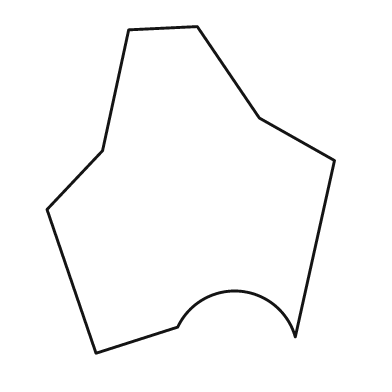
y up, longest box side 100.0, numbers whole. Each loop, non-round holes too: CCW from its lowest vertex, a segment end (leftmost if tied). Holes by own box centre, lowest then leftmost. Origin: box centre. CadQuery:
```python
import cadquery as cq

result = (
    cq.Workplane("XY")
    .moveTo(-29.0, -50.0)
    .lineTo(-4.0, -42.0)
    .threePointArc((15.0, -31.0), (32.0, -45.0))
    .lineTo(44.0, 9.0)
    .lineTo(21.0, 22.0)
    .lineTo(2.0, 50.0)
    .lineTo(-19.0, 49.0)
    .lineTo(-27.0, 12.0)
    .lineTo(-44.0, -6.0)
    .close()
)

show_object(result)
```